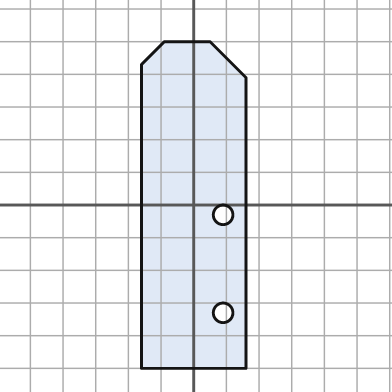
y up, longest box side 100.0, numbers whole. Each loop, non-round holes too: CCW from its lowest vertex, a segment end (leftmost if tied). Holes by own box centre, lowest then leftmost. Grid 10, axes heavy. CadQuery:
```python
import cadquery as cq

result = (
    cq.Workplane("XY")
    .moveTo(-16.0, -50.0)
    .lineTo(16.0, -50.0)
    .lineTo(16.0, 39.0)
    .lineTo(5.0, 50.0)
    .lineTo(-9.0, 50.0)
    .lineTo(-16.0, 43.0)
    .close()
    .moveTo(9.0, -33.0)
    .circle(3.0)
    .moveTo(9.0, -3.0)
    .circle(3.0)
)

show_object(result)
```